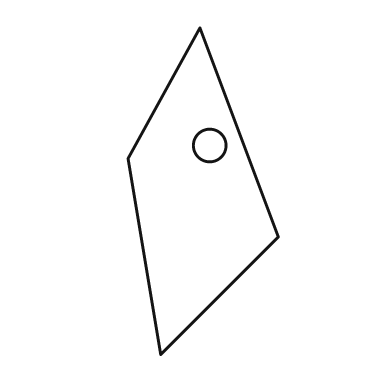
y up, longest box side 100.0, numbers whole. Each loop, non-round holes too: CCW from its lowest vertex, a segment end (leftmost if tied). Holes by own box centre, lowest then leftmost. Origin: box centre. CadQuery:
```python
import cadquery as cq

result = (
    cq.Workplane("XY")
    .moveTo(-13.0, -50.0)
    .lineTo(23.0, -14.0)
    .lineTo(-1.0, 50.0)
    .lineTo(-23.0, 10.0)
    .close()
    .moveTo(2.0, 14.0)
    .circle(5.0)
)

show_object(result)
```